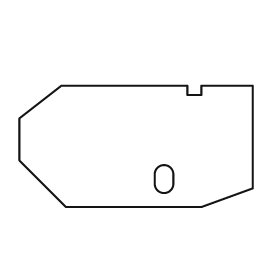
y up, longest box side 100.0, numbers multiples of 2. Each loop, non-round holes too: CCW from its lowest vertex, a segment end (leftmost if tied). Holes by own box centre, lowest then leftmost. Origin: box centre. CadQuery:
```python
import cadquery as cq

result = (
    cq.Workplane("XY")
    .moveTo(-30.0, -26.0)
    .lineTo(28.0, -26.0)
    .lineTo(50.0, -18.0)
    .lineTo(50.0, 26.0)
    .lineTo(28.0, 26.0)
    .lineTo(28.0, 22.0)
    .lineTo(22.0, 22.0)
    .lineTo(22.0, 26.0)
    .lineTo(-32.0, 26.0)
    .lineTo(-50.0, 12.0)
    .lineTo(-50.0, -6.0)
    .close()
    .moveTo(8.0, -16.0)
    .threePointArc((12.0, -20.0), (16.0, -16.0))
    .lineTo(16.0, -12.0)
    .threePointArc((12.0, -8.0), (8.0, -12.0))
    .close()
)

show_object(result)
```